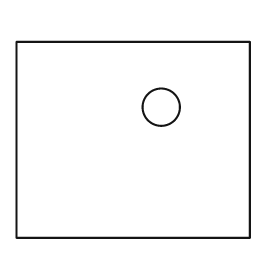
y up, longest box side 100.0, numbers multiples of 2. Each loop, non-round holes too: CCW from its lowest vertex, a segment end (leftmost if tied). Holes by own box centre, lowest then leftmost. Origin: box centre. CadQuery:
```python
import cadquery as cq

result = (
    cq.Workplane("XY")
    .moveTo(-50.0, -42.0)
    .lineTo(50.0, -42.0)
    .lineTo(50.0, 42.0)
    .lineTo(-50.0, 42.0)
    .close()
    .moveTo(12.0, 14.0)
    .circle(8.0)
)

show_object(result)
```